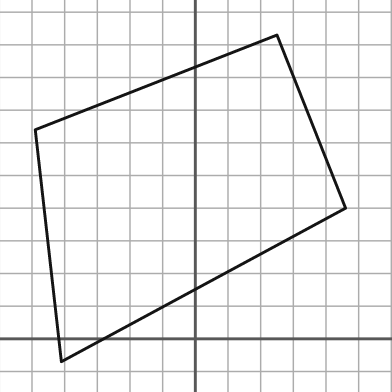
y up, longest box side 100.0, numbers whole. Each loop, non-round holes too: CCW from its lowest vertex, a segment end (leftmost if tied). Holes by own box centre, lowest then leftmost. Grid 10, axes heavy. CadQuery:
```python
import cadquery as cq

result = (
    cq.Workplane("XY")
    .moveTo(-41.0, -7.0)
    .lineTo(46.0, 40.0)
    .lineTo(25.0, 93.0)
    .lineTo(-49.0, 64.0)
    .close()
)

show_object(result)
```